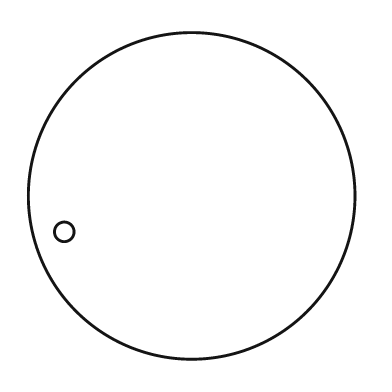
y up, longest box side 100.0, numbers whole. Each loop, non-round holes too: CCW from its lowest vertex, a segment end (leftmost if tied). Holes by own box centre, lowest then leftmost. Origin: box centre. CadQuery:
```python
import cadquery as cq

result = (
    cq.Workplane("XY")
    .moveTo(0.0, 0.0)
    .circle(50.0)
    .moveTo(-39.0, -11.0)
    .circle(3.0)
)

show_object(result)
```